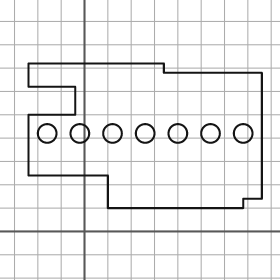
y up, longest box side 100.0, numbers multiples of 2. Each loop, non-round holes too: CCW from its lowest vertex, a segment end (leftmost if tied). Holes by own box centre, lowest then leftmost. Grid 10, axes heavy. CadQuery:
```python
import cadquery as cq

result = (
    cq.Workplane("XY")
    .moveTo(10.0, 10.0)
    .lineTo(68.0, 10.0)
    .lineTo(68.0, 14.0)
    .lineTo(76.0, 14.0)
    .lineTo(76.0, 68.0)
    .lineTo(34.0, 68.0)
    .lineTo(34.0, 72.0)
    .lineTo(-24.0, 72.0)
    .lineTo(-24.0, 62.0)
    .lineTo(-4.0, 62.0)
    .lineTo(-4.0, 50.0)
    .lineTo(-24.0, 50.0)
    .lineTo(-24.0, 24.0)
    .lineTo(10.0, 24.0)
    .close()
    .moveTo(-16.0, 42.0)
    .circle(4.0)
    .moveTo(-2.0, 42.0)
    .circle(4.0)
    .moveTo(12.0, 42.0)
    .circle(4.0)
    .moveTo(26.0, 42.0)
    .circle(4.0)
    .moveTo(40.0, 42.0)
    .circle(4.0)
    .moveTo(54.0, 42.0)
    .circle(4.0)
    .moveTo(68.0, 42.0)
    .circle(4.0)
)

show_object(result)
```